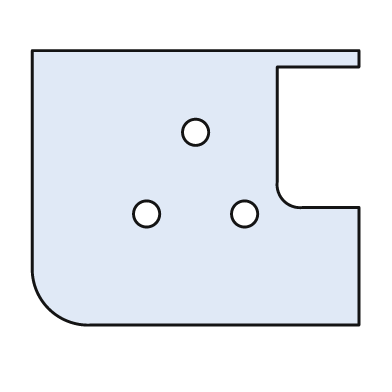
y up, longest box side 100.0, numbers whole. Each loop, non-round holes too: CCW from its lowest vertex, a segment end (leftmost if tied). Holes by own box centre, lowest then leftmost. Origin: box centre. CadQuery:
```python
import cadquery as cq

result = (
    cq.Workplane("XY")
    .moveTo(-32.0, -42.0)
    .lineTo(50.0, -42.0)
    .lineTo(50.0, -6.0)
    .lineTo(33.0, -6.0)
    .threePointArc((27.0, -4.0), (25.0, 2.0))
    .lineTo(25.0, 37.0)
    .lineTo(50.0, 37.0)
    .lineTo(50.0, 42.0)
    .lineTo(-50.0, 42.0)
    .lineTo(-50.0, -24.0)
    .threePointArc((-45.0, -37.0), (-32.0, -42.0))
    .close()
    .moveTo(-15.0, -8.0)
    .circle(4.0)
    .moveTo(15.0, -8.0)
    .circle(4.0)
    .moveTo(0.0, 17.0)
    .circle(4.0)
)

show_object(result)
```